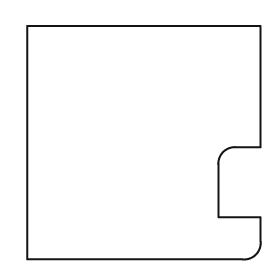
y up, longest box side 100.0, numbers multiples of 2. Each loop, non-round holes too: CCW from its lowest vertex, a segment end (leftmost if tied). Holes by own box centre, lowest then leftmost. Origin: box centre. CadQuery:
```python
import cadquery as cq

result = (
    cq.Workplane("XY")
    .moveTo(-50.0, -50.0)
    .lineTo(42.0, -50.0)
    .threePointArc((48.0, -48.0), (50.0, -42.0))
    .lineTo(50.0, -32.0)
    .lineTo(32.0, -32.0)
    .lineTo(32.0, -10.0)
    .threePointArc((34.0, -4.0), (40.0, -2.0))
    .lineTo(50.0, -2.0)
    .lineTo(50.0, 50.0)
    .lineTo(-50.0, 50.0)
    .close()
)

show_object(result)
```